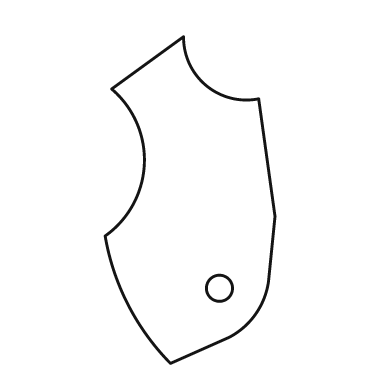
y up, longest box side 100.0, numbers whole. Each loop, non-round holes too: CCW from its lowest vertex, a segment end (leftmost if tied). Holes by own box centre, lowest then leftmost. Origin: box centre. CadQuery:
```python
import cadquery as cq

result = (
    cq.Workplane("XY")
    .moveTo(-6.0, -50.0)
    .lineTo(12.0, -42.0)
    .threePointArc((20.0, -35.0), (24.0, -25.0))
    .lineTo(26.0, -5.0)
    .lineTo(21.0, 31.0)
    .threePointArc((5.0, 35.0), (-2.0, 50.0))
    .lineTo(-24.0, 34.0)
    .threePointArc((-14.0, 11.0), (-26.0, -11.0))
    .threePointArc((-19.0, -32.0), (-6.0, -50.0))
    .close()
    .moveTo(9.0, -27.0)
    .circle(4.0)
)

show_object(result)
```